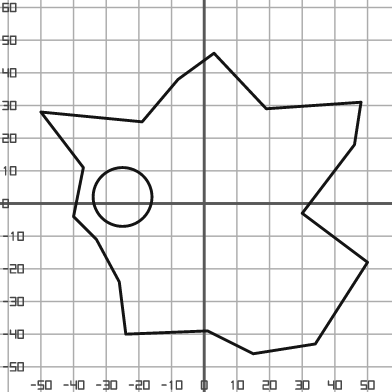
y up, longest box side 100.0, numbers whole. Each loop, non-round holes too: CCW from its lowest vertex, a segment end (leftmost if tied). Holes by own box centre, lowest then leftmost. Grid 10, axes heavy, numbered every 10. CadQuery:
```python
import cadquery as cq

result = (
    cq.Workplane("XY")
    .moveTo(15.0, -46.0)
    .lineTo(34.0, -43.0)
    .lineTo(50.0, -18.0)
    .lineTo(30.0, -3.0)
    .lineTo(46.0, 18.0)
    .lineTo(48.0, 31.0)
    .lineTo(19.0, 29.0)
    .lineTo(3.0, 46.0)
    .lineTo(-8.0, 38.0)
    .lineTo(-19.0, 25.0)
    .lineTo(-50.0, 28.0)
    .lineTo(-37.0, 11.0)
    .lineTo(-40.0, -4.0)
    .lineTo(-33.0, -11.0)
    .lineTo(-26.0, -24.0)
    .lineTo(-24.0, -40.0)
    .lineTo(1.0, -39.0)
    .close()
    .moveTo(-25.0, 2.0)
    .circle(9.0)
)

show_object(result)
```